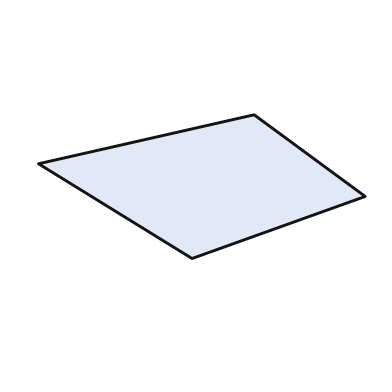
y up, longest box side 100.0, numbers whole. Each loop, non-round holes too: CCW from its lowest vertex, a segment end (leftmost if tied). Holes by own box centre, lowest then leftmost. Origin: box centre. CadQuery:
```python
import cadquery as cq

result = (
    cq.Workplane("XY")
    .moveTo(-3.0, -22.0)
    .lineTo(50.0, -3.0)
    .lineTo(16.0, 22.0)
    .lineTo(-50.0, 7.0)
    .close()
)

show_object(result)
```